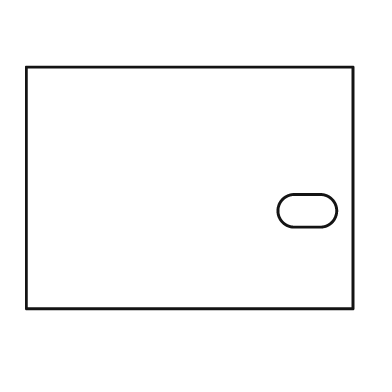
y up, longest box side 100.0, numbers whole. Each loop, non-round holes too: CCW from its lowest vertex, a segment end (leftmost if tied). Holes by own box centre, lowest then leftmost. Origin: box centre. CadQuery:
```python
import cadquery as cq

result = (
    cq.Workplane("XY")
    .moveTo(-50.0, -37.0)
    .lineTo(50.0, -37.0)
    .lineTo(50.0, 37.0)
    .lineTo(-50.0, 37.0)
    .close()
    .moveTo(32.0, -12.0)
    .lineTo(40.0, -12.0)
    .threePointArc((45.0, -7.0), (40.0, -2.0))
    .lineTo(32.0, -2.0)
    .threePointArc((27.0, -7.0), (32.0, -12.0))
    .close()
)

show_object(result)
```